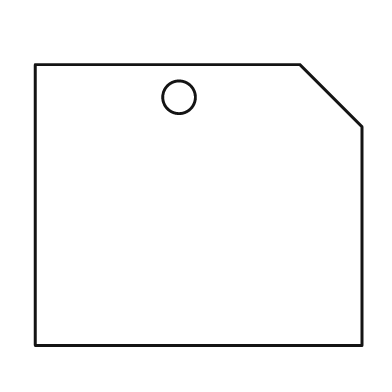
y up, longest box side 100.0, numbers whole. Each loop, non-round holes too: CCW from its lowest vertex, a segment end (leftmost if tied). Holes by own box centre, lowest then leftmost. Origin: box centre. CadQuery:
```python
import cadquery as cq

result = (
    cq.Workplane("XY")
    .moveTo(-50.0, -43.0)
    .lineTo(50.0, -43.0)
    .lineTo(50.0, 24.0)
    .lineTo(31.0, 43.0)
    .lineTo(-50.0, 43.0)
    .close()
    .moveTo(-6.0, 33.0)
    .circle(5.0)
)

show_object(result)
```